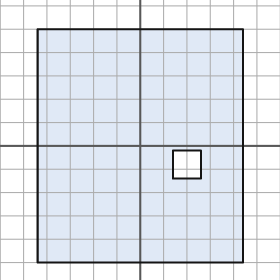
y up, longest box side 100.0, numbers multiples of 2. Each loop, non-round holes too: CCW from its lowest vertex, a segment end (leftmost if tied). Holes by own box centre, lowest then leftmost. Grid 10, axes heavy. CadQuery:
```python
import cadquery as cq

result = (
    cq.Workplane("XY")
    .moveTo(-44.0, -50.0)
    .lineTo(44.0, -50.0)
    .lineTo(44.0, 50.0)
    .lineTo(-44.0, 50.0)
    .close()
    .moveTo(14.0, -14.0)
    .lineTo(26.0, -14.0)
    .lineTo(26.0, -2.0)
    .lineTo(14.0, -2.0)
    .close()
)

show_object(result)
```